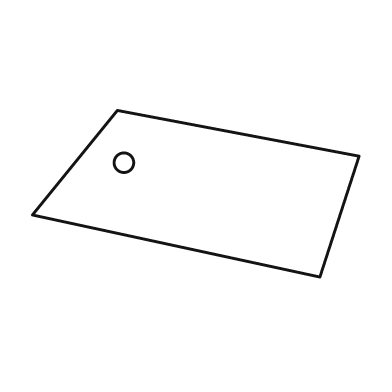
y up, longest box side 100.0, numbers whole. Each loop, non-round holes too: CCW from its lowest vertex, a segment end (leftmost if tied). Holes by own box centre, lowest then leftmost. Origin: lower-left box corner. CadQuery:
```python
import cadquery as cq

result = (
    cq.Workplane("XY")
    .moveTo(88.0, 0.0)
    .lineTo(100.0, 37.0)
    .lineTo(26.0, 51.0)
    .lineTo(0.0, 19.0)
    .close()
    .moveTo(28.0, 35.0)
    .circle(3.0)
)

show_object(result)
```